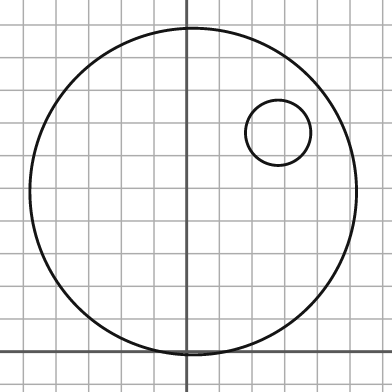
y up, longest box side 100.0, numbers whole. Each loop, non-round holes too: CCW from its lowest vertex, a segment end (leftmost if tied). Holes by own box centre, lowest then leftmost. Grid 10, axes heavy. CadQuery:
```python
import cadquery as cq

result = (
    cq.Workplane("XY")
    .moveTo(2.0, 49.0)
    .circle(50.0)
    .moveTo(28.0, 67.0)
    .circle(10.0)
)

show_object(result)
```